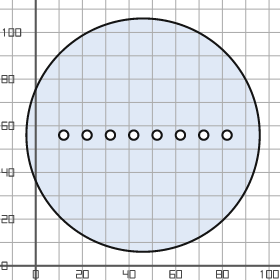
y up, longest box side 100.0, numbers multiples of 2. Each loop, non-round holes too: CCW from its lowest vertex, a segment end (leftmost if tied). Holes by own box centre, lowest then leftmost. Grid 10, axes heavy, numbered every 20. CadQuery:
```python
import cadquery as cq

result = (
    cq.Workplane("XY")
    .moveTo(46.0, 56.0)
    .circle(50.0)
    .moveTo(12.0, 56.0)
    .circle(2.0)
    .moveTo(22.0, 56.0)
    .circle(2.0)
    .moveTo(32.0, 56.0)
    .circle(2.0)
    .moveTo(42.0, 56.0)
    .circle(2.0)
    .moveTo(52.0, 56.0)
    .circle(2.0)
    .moveTo(62.0, 56.0)
    .circle(2.0)
    .moveTo(72.0, 56.0)
    .circle(2.0)
    .moveTo(82.0, 56.0)
    .circle(2.0)
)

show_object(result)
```